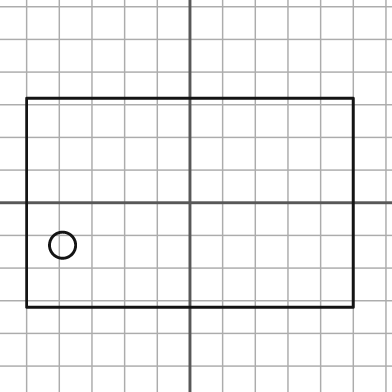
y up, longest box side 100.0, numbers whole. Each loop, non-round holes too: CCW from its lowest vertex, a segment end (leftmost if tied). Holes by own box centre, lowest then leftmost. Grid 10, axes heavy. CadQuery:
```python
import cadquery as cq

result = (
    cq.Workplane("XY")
    .moveTo(-50.0, -32.0)
    .lineTo(50.0, -32.0)
    .lineTo(50.0, 32.0)
    .lineTo(-50.0, 32.0)
    .close()
    .moveTo(-39.0, -13.0)
    .circle(4.0)
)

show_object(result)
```